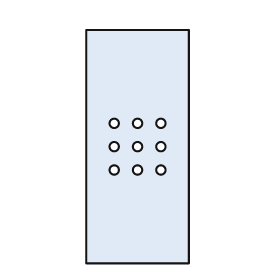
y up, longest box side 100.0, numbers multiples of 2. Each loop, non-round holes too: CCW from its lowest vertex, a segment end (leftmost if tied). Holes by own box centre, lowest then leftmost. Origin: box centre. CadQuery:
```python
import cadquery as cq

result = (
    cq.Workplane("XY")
    .moveTo(-22.0, -50.0)
    .lineTo(22.0, -50.0)
    .lineTo(22.0, 50.0)
    .lineTo(-22.0, 50.0)
    .close()
    .moveTo(-10.0, -10.0)
    .circle(2.0)
    .moveTo(0.0, -10.0)
    .circle(2.0)
    .moveTo(10.0, -10.0)
    .circle(2.0)
    .moveTo(-10.0, 0.0)
    .circle(2.0)
    .moveTo(0.0, 0.0)
    .circle(2.0)
    .moveTo(10.0, 0.0)
    .circle(2.0)
    .moveTo(-10.0, 10.0)
    .circle(2.0)
    .moveTo(0.0, 10.0)
    .circle(2.0)
    .moveTo(10.0, 10.0)
    .circle(2.0)
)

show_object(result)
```